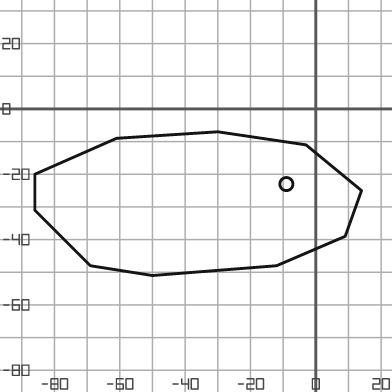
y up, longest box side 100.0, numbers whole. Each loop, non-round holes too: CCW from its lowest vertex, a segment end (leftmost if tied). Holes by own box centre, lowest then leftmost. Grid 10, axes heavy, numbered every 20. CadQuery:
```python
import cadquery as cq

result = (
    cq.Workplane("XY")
    .moveTo(-50.0, -51.0)
    .lineTo(-12.0, -48.0)
    .lineTo(9.0, -39.0)
    .lineTo(14.0, -25.0)
    .lineTo(-3.0, -11.0)
    .lineTo(-30.0, -7.0)
    .lineTo(-61.0, -9.0)
    .lineTo(-86.0, -20.0)
    .lineTo(-86.0, -31.0)
    .lineTo(-69.0, -48.0)
    .close()
    .moveTo(-9.0, -23.0)
    .circle(2.0)
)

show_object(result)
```